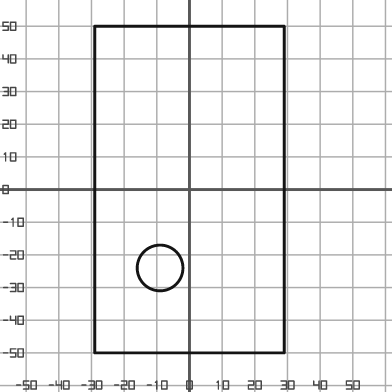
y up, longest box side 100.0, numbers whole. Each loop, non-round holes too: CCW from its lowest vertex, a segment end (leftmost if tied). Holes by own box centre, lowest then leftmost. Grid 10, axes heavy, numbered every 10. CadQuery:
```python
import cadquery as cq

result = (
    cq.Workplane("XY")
    .moveTo(-29.0, -50.0)
    .lineTo(29.0, -50.0)
    .lineTo(29.0, 50.0)
    .lineTo(-29.0, 50.0)
    .close()
    .moveTo(-9.0, -24.0)
    .circle(7.0)
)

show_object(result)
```